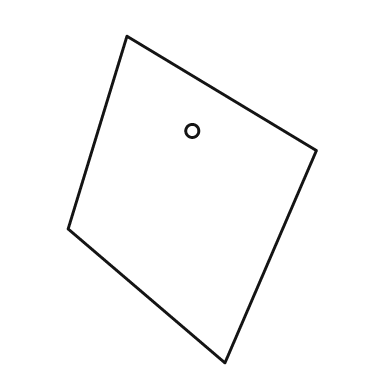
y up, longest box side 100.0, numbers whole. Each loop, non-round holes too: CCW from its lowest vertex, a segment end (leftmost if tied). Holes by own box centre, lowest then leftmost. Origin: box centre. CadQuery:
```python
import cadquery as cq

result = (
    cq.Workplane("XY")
    .moveTo(10.0, -50.0)
    .lineTo(38.0, 15.0)
    .lineTo(-20.0, 50.0)
    .lineTo(-38.0, -9.0)
    .close()
    .moveTo(0.0, 21.0)
    .circle(2.0)
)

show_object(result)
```